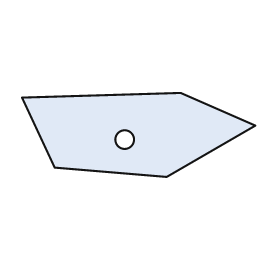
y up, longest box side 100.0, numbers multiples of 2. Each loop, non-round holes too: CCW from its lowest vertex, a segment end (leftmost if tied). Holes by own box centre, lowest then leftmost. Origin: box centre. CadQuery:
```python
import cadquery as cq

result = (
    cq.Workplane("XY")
    .moveTo(12.0, -18.0)
    .lineTo(50.0, 4.0)
    .lineTo(18.0, 18.0)
    .lineTo(-50.0, 16.0)
    .lineTo(-36.0, -14.0)
    .close()
    .moveTo(-6.0, -2.0)
    .circle(4.0)
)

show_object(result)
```